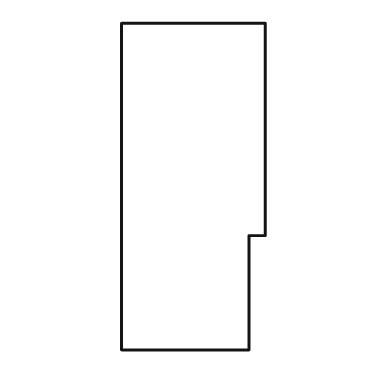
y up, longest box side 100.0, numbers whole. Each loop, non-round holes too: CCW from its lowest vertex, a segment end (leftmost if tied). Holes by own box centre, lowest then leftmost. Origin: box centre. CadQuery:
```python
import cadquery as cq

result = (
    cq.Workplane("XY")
    .moveTo(-22.0, -50.0)
    .lineTo(17.0, -50.0)
    .lineTo(17.0, -15.0)
    .lineTo(22.0, -15.0)
    .lineTo(22.0, 50.0)
    .lineTo(-22.0, 50.0)
    .close()
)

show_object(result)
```